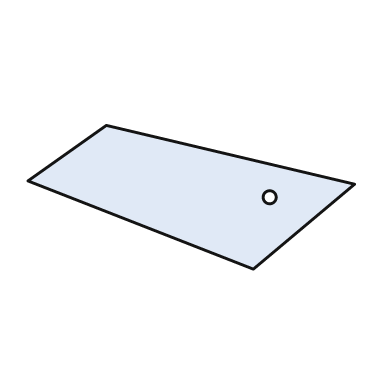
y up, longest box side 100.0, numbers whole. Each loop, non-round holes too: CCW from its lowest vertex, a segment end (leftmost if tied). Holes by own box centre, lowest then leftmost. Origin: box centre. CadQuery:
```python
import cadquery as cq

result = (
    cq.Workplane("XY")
    .moveTo(19.0, -22.0)
    .lineTo(50.0, 4.0)
    .lineTo(-26.0, 22.0)
    .lineTo(-50.0, 5.0)
    .close()
    .moveTo(24.0, 0.0)
    .circle(2.0)
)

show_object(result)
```